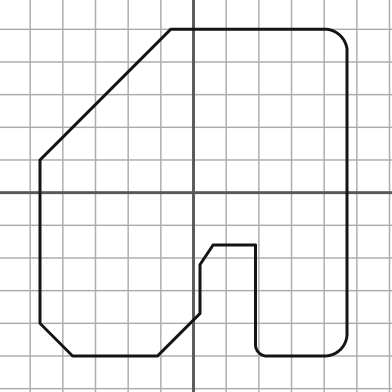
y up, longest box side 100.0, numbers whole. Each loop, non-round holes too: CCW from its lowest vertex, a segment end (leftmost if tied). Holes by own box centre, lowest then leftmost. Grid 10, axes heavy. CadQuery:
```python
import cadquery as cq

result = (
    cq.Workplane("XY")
    .moveTo(-37.0, -50.0)
    .lineTo(-11.0, -50.0)
    .lineTo(2.0, -37.0)
    .lineTo(2.0, -22.0)
    .lineTo(6.0, -16.0)
    .lineTo(19.0, -16.0)
    .lineTo(19.0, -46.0)
    .threePointArc((20.0, -49.0), (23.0, -50.0))
    .lineTo(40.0, -50.0)
    .threePointArc((45.0, -48.0), (47.0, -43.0))
    .lineTo(47.0, 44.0)
    .threePointArc((45.0, 48.0), (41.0, 50.0))
    .lineTo(-7.0, 50.0)
    .lineTo(-47.0, 10.0)
    .lineTo(-47.0, -40.0)
    .close()
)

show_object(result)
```